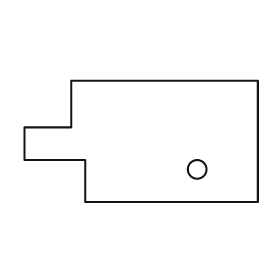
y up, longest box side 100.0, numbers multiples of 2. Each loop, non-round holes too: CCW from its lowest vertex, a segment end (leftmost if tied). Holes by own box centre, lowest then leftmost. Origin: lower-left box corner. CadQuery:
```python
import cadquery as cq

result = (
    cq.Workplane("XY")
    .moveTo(26.0, 0.0)
    .lineTo(100.0, 0.0)
    .lineTo(100.0, 52.0)
    .lineTo(20.0, 52.0)
    .lineTo(20.0, 32.0)
    .lineTo(0.0, 32.0)
    .lineTo(0.0, 18.0)
    .lineTo(26.0, 18.0)
    .close()
    .moveTo(74.0, 14.0)
    .circle(4.0)
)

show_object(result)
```